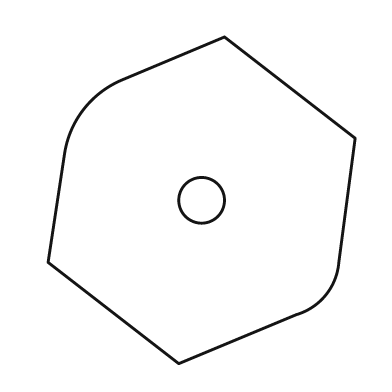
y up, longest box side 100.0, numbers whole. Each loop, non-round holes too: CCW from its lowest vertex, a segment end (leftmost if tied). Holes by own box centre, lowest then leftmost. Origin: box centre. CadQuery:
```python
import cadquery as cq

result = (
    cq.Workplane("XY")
    .moveTo(-7.0, -50.0)
    .lineTo(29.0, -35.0)
    .threePointArc((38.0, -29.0), (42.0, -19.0))
    .lineTo(47.0, 19.0)
    .lineTo(7.0, 50.0)
    .lineTo(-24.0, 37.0)
    .threePointArc((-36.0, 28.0), (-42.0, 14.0))
    .lineTo(-47.0, -19.0)
    .close()
    .moveTo(0.0, 0.0)
    .circle(7.0)
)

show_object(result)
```